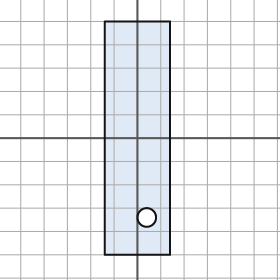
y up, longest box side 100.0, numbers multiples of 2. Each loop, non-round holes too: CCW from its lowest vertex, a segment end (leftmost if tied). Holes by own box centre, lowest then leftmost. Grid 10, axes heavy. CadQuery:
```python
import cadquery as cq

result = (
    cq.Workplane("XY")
    .moveTo(-14.0, -50.0)
    .lineTo(14.0, -50.0)
    .lineTo(14.0, 50.0)
    .lineTo(-14.0, 50.0)
    .close()
    .moveTo(4.0, -34.0)
    .circle(4.0)
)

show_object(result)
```